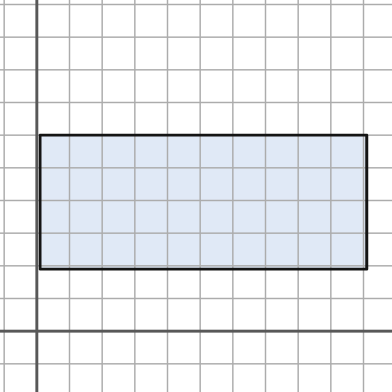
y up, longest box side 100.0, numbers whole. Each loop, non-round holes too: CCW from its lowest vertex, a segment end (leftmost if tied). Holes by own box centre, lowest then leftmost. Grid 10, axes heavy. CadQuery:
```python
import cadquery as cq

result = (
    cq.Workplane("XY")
    .moveTo(1.0, 19.0)
    .lineTo(101.0, 19.0)
    .lineTo(101.0, 60.0)
    .lineTo(1.0, 60.0)
    .close()
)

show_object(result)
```